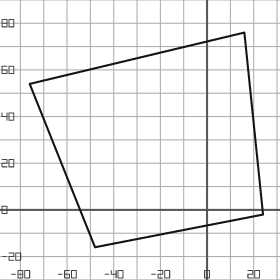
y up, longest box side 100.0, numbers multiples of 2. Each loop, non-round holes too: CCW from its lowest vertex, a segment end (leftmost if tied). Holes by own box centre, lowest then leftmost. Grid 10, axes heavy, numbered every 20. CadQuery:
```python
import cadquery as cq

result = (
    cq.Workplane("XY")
    .moveTo(-48.0, -16.0)
    .lineTo(24.0, -2.0)
    .lineTo(16.0, 76.0)
    .lineTo(-76.0, 54.0)
    .close()
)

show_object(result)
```